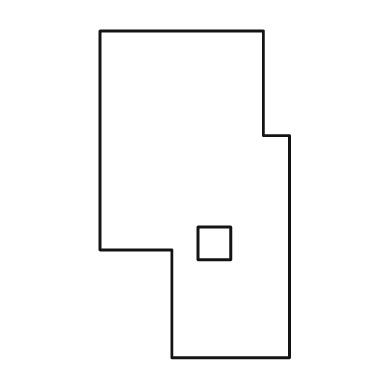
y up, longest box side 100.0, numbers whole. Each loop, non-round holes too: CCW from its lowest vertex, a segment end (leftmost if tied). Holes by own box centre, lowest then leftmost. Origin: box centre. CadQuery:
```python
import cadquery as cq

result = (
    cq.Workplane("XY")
    .moveTo(-7.0, -50.0)
    .lineTo(29.0, -50.0)
    .lineTo(29.0, 18.0)
    .lineTo(21.0, 18.0)
    .lineTo(21.0, 50.0)
    .lineTo(-29.0, 50.0)
    .lineTo(-29.0, -17.0)
    .lineTo(-7.0, -17.0)
    .close()
    .moveTo(1.0, -20.0)
    .lineTo(11.0, -20.0)
    .lineTo(11.0, -10.0)
    .lineTo(1.0, -10.0)
    .close()
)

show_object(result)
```